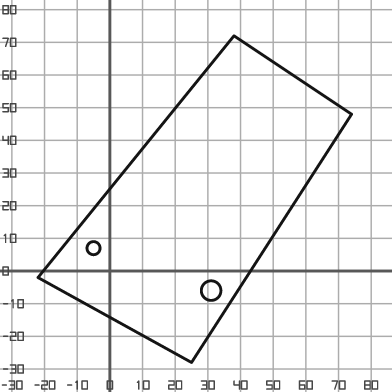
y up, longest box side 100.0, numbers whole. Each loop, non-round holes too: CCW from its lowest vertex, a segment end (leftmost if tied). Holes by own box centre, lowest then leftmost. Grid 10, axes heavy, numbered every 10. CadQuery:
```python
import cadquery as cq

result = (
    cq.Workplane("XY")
    .moveTo(25.0, -28.0)
    .lineTo(74.0, 48.0)
    .lineTo(38.0, 72.0)
    .lineTo(-22.0, -2.0)
    .close()
    .moveTo(31.0, -6.0)
    .circle(3.0)
    .moveTo(-5.0, 7.0)
    .circle(2.0)
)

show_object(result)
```